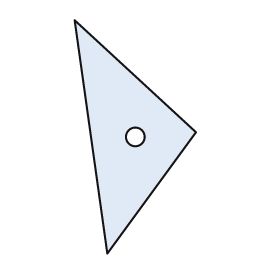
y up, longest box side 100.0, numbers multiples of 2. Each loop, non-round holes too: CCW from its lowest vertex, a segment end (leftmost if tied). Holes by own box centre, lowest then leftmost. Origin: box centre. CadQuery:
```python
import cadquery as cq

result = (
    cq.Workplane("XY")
    .moveTo(-12.0, -50.0)
    .lineTo(26.0, 2.0)
    .lineTo(-26.0, 50.0)
    .close()
    .moveTo(0.0, 0.0)
    .circle(4.0)
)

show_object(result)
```